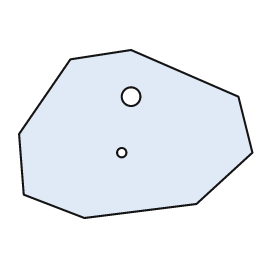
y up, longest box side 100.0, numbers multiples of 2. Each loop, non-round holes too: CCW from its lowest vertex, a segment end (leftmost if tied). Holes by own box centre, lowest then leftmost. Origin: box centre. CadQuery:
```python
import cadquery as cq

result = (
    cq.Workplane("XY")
    .moveTo(-22.0, -36.0)
    .lineTo(26.0, -30.0)
    .lineTo(50.0, -8.0)
    .lineTo(44.0, 16.0)
    .lineTo(-2.0, 36.0)
    .lineTo(-28.0, 32.0)
    .lineTo(-50.0, 0.0)
    .lineTo(-48.0, -26.0)
    .close()
    .moveTo(-6.0, -8.0)
    .circle(2.0)
    .moveTo(-2.0, 16.0)
    .circle(4.0)
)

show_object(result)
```